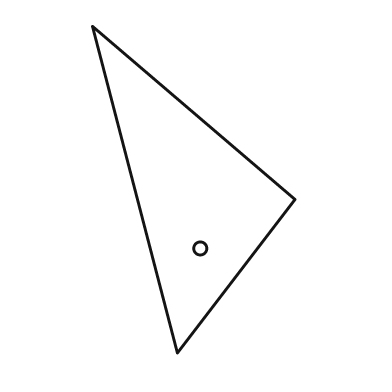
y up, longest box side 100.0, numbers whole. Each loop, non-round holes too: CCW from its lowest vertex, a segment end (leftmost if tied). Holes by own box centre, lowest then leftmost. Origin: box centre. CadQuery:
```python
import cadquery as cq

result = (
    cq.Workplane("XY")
    .moveTo(-5.0, -50.0)
    .lineTo(31.0, -3.0)
    .lineTo(-31.0, 50.0)
    .close()
    .moveTo(2.0, -18.0)
    .circle(2.0)
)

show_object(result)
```